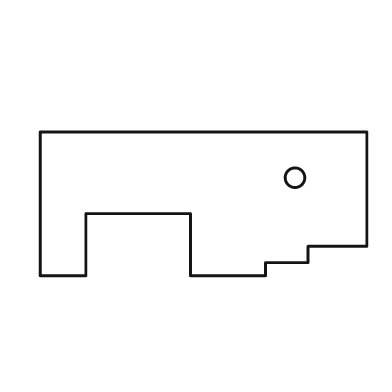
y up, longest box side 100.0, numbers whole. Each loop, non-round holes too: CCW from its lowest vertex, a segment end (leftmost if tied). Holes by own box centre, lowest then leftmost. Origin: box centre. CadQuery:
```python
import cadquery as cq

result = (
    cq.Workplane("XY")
    .moveTo(-50.0, -22.0)
    .lineTo(-36.0, -22.0)
    .lineTo(-36.0, -3.0)
    .lineTo(-4.0, -3.0)
    .lineTo(-4.0, -22.0)
    .lineTo(19.0, -22.0)
    .lineTo(19.0, -18.0)
    .lineTo(32.0, -18.0)
    .lineTo(32.0, -13.0)
    .lineTo(50.0, -13.0)
    .lineTo(50.0, 22.0)
    .lineTo(-50.0, 22.0)
    .close()
    .moveTo(28.0, 8.0)
    .circle(3.0)
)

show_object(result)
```